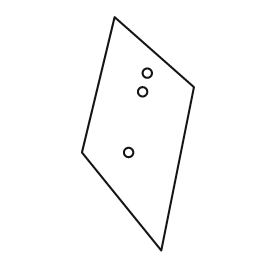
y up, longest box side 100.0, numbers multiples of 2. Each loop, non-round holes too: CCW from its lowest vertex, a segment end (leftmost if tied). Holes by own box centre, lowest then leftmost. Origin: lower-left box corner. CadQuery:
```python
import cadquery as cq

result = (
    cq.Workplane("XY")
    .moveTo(34.0, 0.0)
    .lineTo(48.0, 70.0)
    .lineTo(14.0, 100.0)
    .lineTo(0.0, 42.0)
    .close()
    .moveTo(20.0, 42.0)
    .circle(2.0)
    .moveTo(26.0, 68.0)
    .circle(2.0)
    .moveTo(28.0, 76.0)
    .circle(2.0)
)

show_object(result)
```